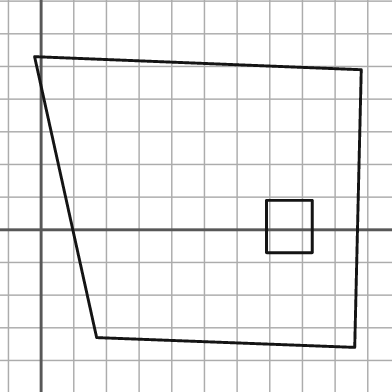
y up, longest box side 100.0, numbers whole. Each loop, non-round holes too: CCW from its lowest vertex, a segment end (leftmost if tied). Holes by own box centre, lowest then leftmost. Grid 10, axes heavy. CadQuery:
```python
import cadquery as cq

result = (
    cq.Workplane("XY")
    .moveTo(96.0, -36.0)
    .lineTo(98.0, 49.0)
    .lineTo(-2.0, 53.0)
    .lineTo(17.0, -33.0)
    .close()
    .moveTo(69.0, -7.0)
    .lineTo(83.0, -7.0)
    .lineTo(83.0, 9.0)
    .lineTo(69.0, 9.0)
    .close()
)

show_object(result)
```